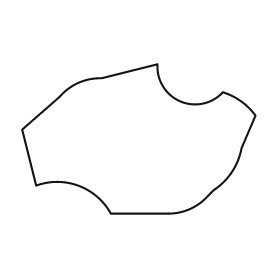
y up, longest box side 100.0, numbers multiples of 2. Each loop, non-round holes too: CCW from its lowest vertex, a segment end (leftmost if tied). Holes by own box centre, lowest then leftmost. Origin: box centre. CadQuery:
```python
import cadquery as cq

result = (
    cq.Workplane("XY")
    .moveTo(-12.0, -32.0)
    .lineTo(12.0, -32.0)
    .threePointArc((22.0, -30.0), (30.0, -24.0))
    .lineTo(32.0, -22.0)
    .threePointArc((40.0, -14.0), (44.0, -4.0))
    .lineTo(50.0, 10.0)
    .threePointArc((44.0, 16.0), (36.0, 20.0))
    .threePointArc((18.0, 16.0), (8.0, 32.0))
    .lineTo(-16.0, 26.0)
    .threePointArc((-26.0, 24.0), (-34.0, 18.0))
    .lineTo(-50.0, 4.0)
    .lineTo(-44.0, -20.0)
    .threePointArc((-26.0, -20.0), (-12.0, -32.0))
    .close()
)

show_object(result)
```